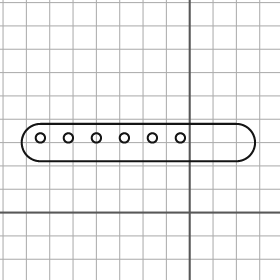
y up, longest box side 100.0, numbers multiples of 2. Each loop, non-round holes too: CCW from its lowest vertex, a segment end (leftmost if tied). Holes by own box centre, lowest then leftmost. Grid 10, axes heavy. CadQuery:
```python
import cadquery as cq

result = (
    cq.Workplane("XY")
    .moveTo(-64.0, 22.0)
    .lineTo(20.0, 22.0)
    .threePointArc((28.0, 30.0), (20.0, 38.0))
    .lineTo(-64.0, 38.0)
    .threePointArc((-72.0, 30.0), (-64.0, 22.0))
    .close()
    .moveTo(-64.0, 32.0)
    .circle(2.0)
    .moveTo(-52.0, 32.0)
    .circle(2.0)
    .moveTo(-40.0, 32.0)
    .circle(2.0)
    .moveTo(-28.0, 32.0)
    .circle(2.0)
    .moveTo(-16.0, 32.0)
    .circle(2.0)
    .moveTo(-4.0, 32.0)
    .circle(2.0)
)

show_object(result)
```